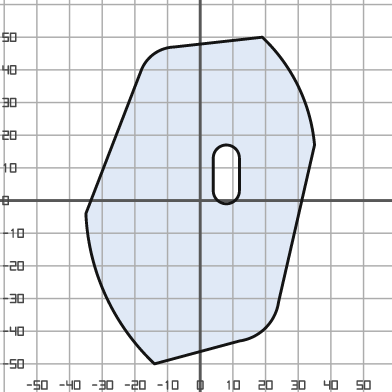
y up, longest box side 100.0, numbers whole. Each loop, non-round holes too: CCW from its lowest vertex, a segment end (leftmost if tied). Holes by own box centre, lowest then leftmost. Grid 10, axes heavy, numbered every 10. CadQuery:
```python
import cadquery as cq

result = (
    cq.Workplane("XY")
    .moveTo(-14.0, -50.0)
    .lineTo(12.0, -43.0)
    .threePointArc((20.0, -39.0), (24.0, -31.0))
    .lineTo(35.0, 17.0)
    .threePointArc((30.0, 35.0), (19.0, 50.0))
    .lineTo(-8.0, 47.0)
    .threePointArc((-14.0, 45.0), (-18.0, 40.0))
    .lineTo(-35.0, -4.0)
    .threePointArc((-29.0, -29.0), (-14.0, -50.0))
    .close()
    .moveTo(4.0, 3.0)
    .threePointArc((8.0, -1.0), (12.0, 3.0))
    .lineTo(12.0, 13.0)
    .threePointArc((8.0, 17.0), (4.0, 13.0))
    .close()
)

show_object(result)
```